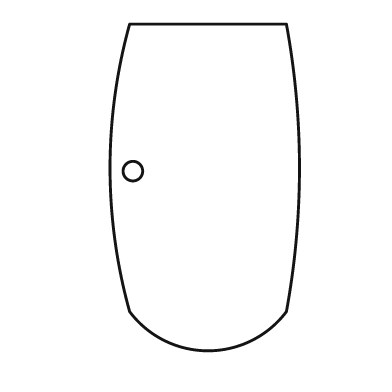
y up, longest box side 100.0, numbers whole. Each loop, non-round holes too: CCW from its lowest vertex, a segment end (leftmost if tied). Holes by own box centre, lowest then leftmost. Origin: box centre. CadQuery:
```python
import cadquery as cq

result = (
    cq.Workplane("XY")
    .moveTo(-23.0, -38.0)
    .threePointArc((1.0, -50.0), (25.0, -38.0))
    .threePointArc((29.0, 6.0), (25.0, 50.0))
    .lineTo(-23.0, 50.0)
    .threePointArc((-29.0, 6.0), (-23.0, -38.0))
    .close()
    .moveTo(-22.0, 5.0)
    .circle(3.0)
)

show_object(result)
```